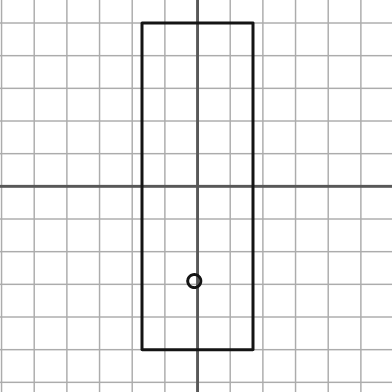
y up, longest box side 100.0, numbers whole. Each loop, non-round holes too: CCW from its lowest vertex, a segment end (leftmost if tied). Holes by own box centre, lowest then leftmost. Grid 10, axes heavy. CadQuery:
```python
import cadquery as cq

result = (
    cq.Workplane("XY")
    .moveTo(-17.0, -50.0)
    .lineTo(17.0, -50.0)
    .lineTo(17.0, 50.0)
    .lineTo(-17.0, 50.0)
    .close()
    .moveTo(-1.0, -29.0)
    .circle(2.0)
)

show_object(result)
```